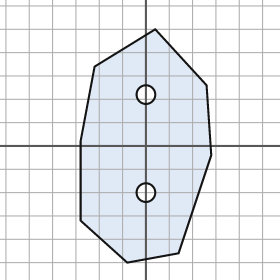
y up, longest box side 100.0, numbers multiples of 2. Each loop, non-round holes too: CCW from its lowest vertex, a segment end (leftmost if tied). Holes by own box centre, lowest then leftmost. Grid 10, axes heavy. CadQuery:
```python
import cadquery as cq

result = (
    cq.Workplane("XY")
    .moveTo(-8.0, -50.0)
    .lineTo(14.0, -46.0)
    .lineTo(28.0, -4.0)
    .lineTo(26.0, 26.0)
    .lineTo(4.0, 50.0)
    .lineTo(-22.0, 34.0)
    .lineTo(-28.0, 2.0)
    .lineTo(-28.0, -32.0)
    .close()
    .moveTo(0.0, -20.0)
    .circle(4.0)
    .moveTo(0.0, 22.0)
    .circle(4.0)
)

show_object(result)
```